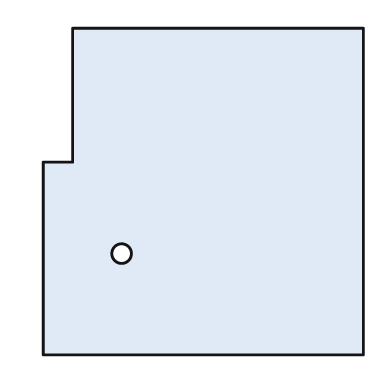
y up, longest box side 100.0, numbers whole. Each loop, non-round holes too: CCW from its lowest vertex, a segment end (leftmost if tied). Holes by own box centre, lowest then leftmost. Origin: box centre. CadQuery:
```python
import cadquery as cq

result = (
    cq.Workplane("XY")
    .moveTo(-49.0, -50.0)
    .lineTo(49.0, -50.0)
    .lineTo(49.0, 50.0)
    .lineTo(-40.0, 50.0)
    .lineTo(-40.0, 9.0)
    .lineTo(-49.0, 9.0)
    .close()
    .moveTo(-25.0, -19.0)
    .circle(3.0)
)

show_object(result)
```